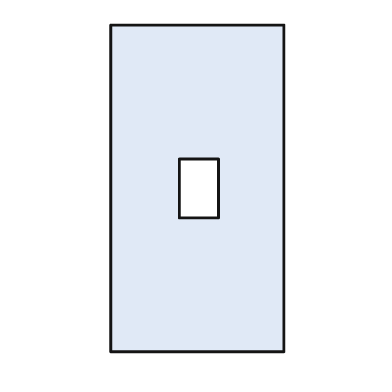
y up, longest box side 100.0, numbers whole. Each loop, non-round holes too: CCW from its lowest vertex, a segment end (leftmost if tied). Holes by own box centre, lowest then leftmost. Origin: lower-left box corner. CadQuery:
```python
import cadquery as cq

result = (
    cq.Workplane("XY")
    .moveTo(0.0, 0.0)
    .lineTo(53.0, 0.0)
    .lineTo(53.0, 100.0)
    .lineTo(0.0, 100.0)
    .close()
    .moveTo(21.0, 41.0)
    .lineTo(33.0, 41.0)
    .lineTo(33.0, 59.0)
    .lineTo(21.0, 59.0)
    .close()
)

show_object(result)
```